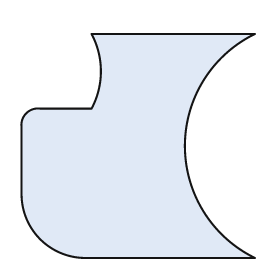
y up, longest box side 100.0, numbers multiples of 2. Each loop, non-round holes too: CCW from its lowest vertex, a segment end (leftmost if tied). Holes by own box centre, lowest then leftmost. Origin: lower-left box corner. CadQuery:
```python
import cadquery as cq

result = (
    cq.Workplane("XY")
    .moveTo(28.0, 0.0)
    .lineTo(100.0, 0.0)
    .threePointArc((70.0, 48.0), (100.0, 96.0))
    .lineTo(30.0, 96.0)
    .threePointArc((34.0, 80.0), (30.0, 64.0))
    .lineTo(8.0, 64.0)
    .threePointArc((2.0, 62.0), (0.0, 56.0))
    .lineTo(0.0, 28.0)
    .threePointArc((8.0, 8.0), (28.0, 0.0))
    .close()
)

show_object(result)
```